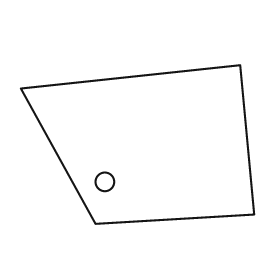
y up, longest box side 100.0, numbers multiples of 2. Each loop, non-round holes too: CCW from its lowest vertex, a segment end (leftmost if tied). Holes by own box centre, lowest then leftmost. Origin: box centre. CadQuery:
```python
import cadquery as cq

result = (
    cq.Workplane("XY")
    .moveTo(-18.0, -34.0)
    .lineTo(50.0, -30.0)
    .lineTo(44.0, 34.0)
    .lineTo(-50.0, 24.0)
    .close()
    .moveTo(-14.0, -16.0)
    .circle(4.0)
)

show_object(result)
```